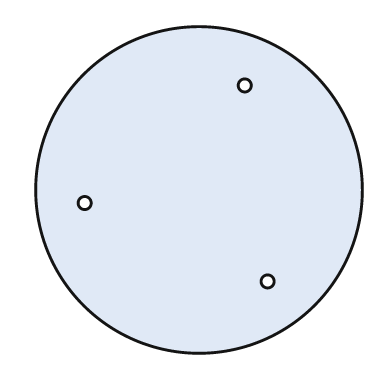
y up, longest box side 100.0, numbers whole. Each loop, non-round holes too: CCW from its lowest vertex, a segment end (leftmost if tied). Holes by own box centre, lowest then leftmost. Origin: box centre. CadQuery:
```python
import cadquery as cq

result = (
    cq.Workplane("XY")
    .moveTo(0.0, 0.0)
    .circle(50.0)
    .moveTo(21.0, -28.0)
    .circle(2.0)
    .moveTo(-35.0, -4.0)
    .circle(2.0)
    .moveTo(14.0, 32.0)
    .circle(2.0)
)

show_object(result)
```